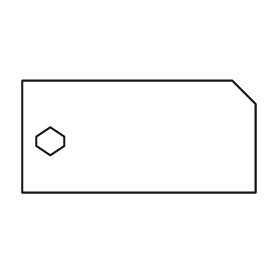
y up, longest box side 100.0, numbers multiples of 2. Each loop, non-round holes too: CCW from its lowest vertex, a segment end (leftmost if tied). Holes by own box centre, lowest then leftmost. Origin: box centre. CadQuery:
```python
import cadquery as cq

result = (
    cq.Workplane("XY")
    .moveTo(-50.0, -24.0)
    .lineTo(50.0, -24.0)
    .lineTo(50.0, 14.0)
    .lineTo(40.0, 24.0)
    .lineTo(-50.0, 24.0)
    .close()
    .moveTo(-38.0, -8.0)
    .lineTo(-32.0, -4.0)
    .lineTo(-32.0, 0.0)
    .lineTo(-38.0, 4.0)
    .lineTo(-44.0, 0.0)
    .lineTo(-44.0, -4.0)
    .close()
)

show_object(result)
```